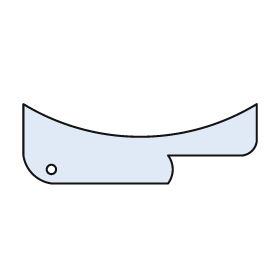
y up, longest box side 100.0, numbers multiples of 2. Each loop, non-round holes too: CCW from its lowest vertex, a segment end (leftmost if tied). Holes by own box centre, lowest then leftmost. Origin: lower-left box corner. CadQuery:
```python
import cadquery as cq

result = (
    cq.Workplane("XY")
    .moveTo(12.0, 0.0)
    .lineTo(62.0, 0.0)
    .threePointArc((64.0, 6.0), (62.0, 12.0))
    .lineTo(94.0, 12.0)
    .threePointArc((98.0, 14.0), (100.0, 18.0))
    .lineTo(100.0, 34.0)
    .threePointArc((50.0, 20.0), (0.0, 34.0))
    .lineTo(0.0, 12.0)
    .threePointArc((4.0, 4.0), (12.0, 0.0))
    .close()
    .moveTo(12.0, 6.0)
    .circle(2.0)
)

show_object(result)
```